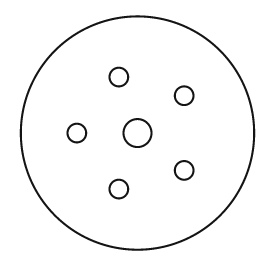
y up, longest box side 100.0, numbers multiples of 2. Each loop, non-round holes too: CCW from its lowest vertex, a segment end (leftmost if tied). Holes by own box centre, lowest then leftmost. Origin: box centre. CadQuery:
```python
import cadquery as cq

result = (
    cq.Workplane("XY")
    .moveTo(0.0, 0.0)
    .circle(50.0)
    .moveTo(-8.0, -24.0)
    .circle(4.0)
    .moveTo(20.0, -16.0)
    .circle(4.0)
    .moveTo(-26.0, 0.0)
    .circle(4.0)
    .moveTo(0.0, 0.0)
    .circle(6.0)
    .moveTo(20.0, 16.0)
    .circle(4.0)
    .moveTo(-8.0, 24.0)
    .circle(4.0)
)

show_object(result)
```